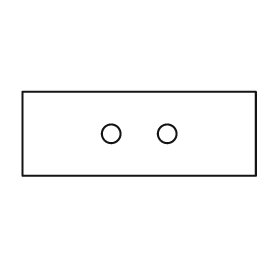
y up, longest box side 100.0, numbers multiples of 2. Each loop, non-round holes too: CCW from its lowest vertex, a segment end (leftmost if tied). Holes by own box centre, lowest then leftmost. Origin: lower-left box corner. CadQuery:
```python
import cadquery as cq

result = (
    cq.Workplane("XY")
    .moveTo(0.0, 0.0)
    .lineTo(100.0, 0.0)
    .lineTo(100.0, 36.0)
    .lineTo(0.0, 36.0)
    .close()
    .moveTo(38.0, 18.0)
    .circle(4.0)
    .moveTo(62.0, 18.0)
    .circle(4.0)
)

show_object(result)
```